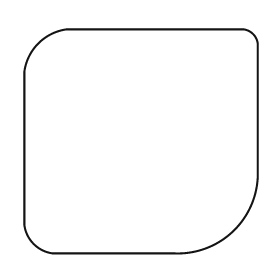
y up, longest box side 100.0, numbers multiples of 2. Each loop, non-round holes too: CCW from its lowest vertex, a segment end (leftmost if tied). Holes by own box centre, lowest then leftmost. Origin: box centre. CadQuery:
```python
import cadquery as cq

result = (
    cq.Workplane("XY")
    .moveTo(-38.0, -48.0)
    .lineTo(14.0, -48.0)
    .threePointArc((40.0, -38.0), (50.0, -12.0))
    .lineTo(50.0, 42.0)
    .threePointArc((48.0, 46.0), (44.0, 48.0))
    .lineTo(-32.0, 48.0)
    .threePointArc((-44.0, 42.0), (-50.0, 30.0))
    .lineTo(-50.0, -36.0)
    .threePointArc((-46.0, -44.0), (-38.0, -48.0))
    .close()
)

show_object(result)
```